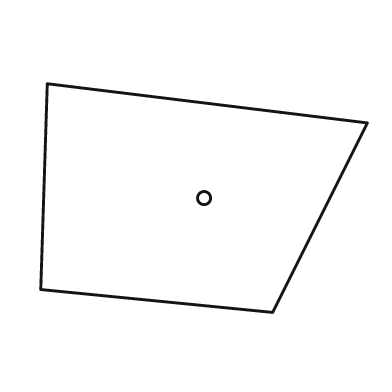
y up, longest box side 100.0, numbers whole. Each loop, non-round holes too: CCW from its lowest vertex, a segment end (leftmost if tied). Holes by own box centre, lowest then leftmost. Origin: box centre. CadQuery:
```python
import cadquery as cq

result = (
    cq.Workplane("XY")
    .moveTo(21.0, -35.0)
    .lineTo(50.0, 23.0)
    .lineTo(-48.0, 35.0)
    .lineTo(-50.0, -28.0)
    .close()
    .moveTo(0.0, 0.0)
    .circle(2.0)
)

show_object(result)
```